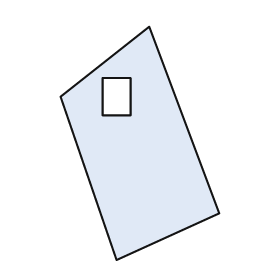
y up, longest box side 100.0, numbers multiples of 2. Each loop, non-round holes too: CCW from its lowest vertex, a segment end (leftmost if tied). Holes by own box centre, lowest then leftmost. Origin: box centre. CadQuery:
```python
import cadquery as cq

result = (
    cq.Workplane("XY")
    .moveTo(-10.0, -50.0)
    .lineTo(34.0, -30.0)
    .lineTo(4.0, 50.0)
    .lineTo(-34.0, 20.0)
    .close()
    .moveTo(-16.0, 12.0)
    .lineTo(-4.0, 12.0)
    .lineTo(-4.0, 28.0)
    .lineTo(-16.0, 28.0)
    .close()
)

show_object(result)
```